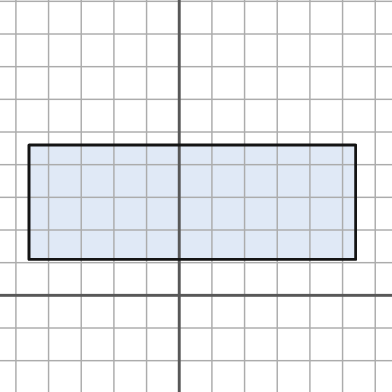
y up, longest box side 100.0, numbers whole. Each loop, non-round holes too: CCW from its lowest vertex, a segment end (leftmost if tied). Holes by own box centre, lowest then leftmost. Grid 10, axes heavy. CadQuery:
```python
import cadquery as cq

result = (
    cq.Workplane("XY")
    .moveTo(-46.0, 11.0)
    .lineTo(54.0, 11.0)
    .lineTo(54.0, 46.0)
    .lineTo(-46.0, 46.0)
    .close()
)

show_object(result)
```